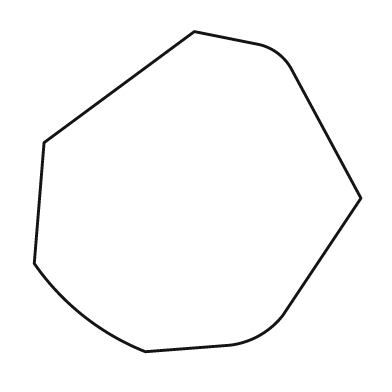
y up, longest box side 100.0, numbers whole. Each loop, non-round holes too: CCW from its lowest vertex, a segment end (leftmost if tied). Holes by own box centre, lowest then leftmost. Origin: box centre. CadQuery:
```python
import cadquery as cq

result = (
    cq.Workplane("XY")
    .moveTo(-16.0, -49.0)
    .lineTo(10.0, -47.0)
    .threePointArc((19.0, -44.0), (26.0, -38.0))
    .lineTo(50.0, -2.0)
    .lineTo(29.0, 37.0)
    .threePointArc((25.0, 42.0), (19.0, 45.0))
    .lineTo(-1.0, 49.0)
    .lineTo(-47.0, 15.0)
    .lineTo(-50.0, -22.0)
    .threePointArc((-35.0, -38.0), (-16.0, -49.0))
    .close()
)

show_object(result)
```